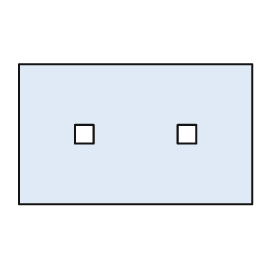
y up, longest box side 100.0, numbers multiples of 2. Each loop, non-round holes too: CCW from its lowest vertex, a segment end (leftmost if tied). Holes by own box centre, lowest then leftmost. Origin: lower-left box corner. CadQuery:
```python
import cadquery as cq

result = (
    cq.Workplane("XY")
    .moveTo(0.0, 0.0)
    .lineTo(100.0, 0.0)
    .lineTo(100.0, 60.0)
    .lineTo(0.0, 60.0)
    .close()
    .moveTo(24.0, 26.0)
    .lineTo(32.0, 26.0)
    .lineTo(32.0, 34.0)
    .lineTo(24.0, 34.0)
    .close()
    .moveTo(68.0, 26.0)
    .lineTo(76.0, 26.0)
    .lineTo(76.0, 34.0)
    .lineTo(68.0, 34.0)
    .close()
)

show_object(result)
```